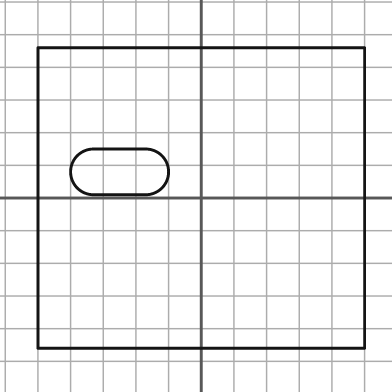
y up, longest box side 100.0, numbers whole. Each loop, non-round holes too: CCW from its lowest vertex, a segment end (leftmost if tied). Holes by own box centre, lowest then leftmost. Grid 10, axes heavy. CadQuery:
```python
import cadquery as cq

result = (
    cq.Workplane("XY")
    .moveTo(-50.0, -46.0)
    .lineTo(50.0, -46.0)
    .lineTo(50.0, 46.0)
    .lineTo(-50.0, 46.0)
    .close()
    .moveTo(-33.0, 1.0)
    .lineTo(-17.0, 1.0)
    .threePointArc((-10.0, 8.0), (-17.0, 15.0))
    .lineTo(-33.0, 15.0)
    .threePointArc((-40.0, 8.0), (-33.0, 1.0))
    .close()
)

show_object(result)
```